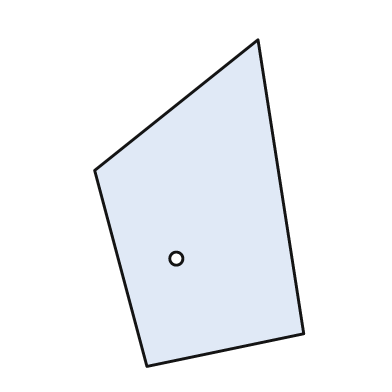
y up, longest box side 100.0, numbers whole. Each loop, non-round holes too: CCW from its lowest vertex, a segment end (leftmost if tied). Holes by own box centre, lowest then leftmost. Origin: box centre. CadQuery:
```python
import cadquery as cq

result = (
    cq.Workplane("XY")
    .moveTo(-16.0, -50.0)
    .lineTo(32.0, -40.0)
    .lineTo(18.0, 50.0)
    .lineTo(-32.0, 10.0)
    .close()
    .moveTo(-7.0, -17.0)
    .circle(2.0)
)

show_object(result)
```